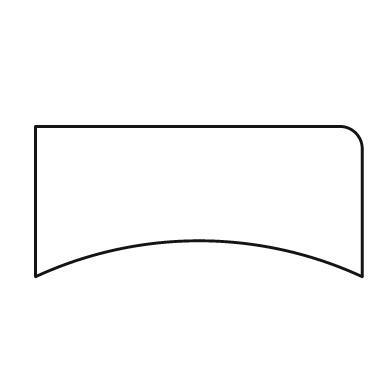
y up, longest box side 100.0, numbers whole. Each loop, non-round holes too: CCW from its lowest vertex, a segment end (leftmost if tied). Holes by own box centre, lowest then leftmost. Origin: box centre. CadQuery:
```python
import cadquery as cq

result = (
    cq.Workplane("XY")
    .moveTo(-50.0, -23.0)
    .threePointArc((0.0, -12.0), (50.0, -23.0))
    .lineTo(50.0, 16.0)
    .threePointArc((48.0, 21.0), (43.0, 23.0))
    .lineTo(-50.0, 23.0)
    .close()
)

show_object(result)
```